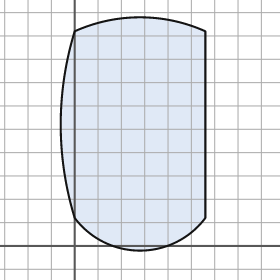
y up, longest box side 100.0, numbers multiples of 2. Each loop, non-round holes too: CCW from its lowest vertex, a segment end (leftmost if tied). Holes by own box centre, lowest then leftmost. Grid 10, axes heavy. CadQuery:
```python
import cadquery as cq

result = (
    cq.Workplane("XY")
    .moveTo(0.0, 12.0)
    .threePointArc((28.0, -2.0), (56.0, 12.0))
    .lineTo(56.0, 92.0)
    .threePointArc((28.0, 98.0), (0.0, 92.0))
    .threePointArc((-6.0, 52.0), (0.0, 12.0))
    .close()
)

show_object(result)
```